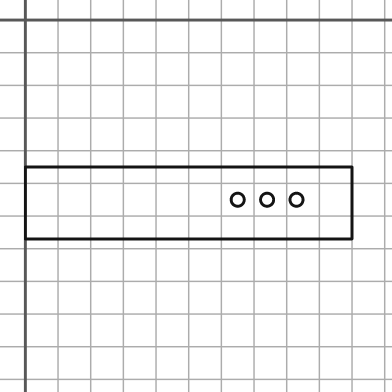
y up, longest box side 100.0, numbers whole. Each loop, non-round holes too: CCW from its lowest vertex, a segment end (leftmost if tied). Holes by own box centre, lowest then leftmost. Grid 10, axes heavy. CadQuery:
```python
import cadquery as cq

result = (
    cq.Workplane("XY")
    .moveTo(0.0, -67.0)
    .lineTo(100.0, -67.0)
    .lineTo(100.0, -45.0)
    .lineTo(0.0, -45.0)
    .close()
    .moveTo(65.0, -55.0)
    .circle(2.0)
    .moveTo(74.0, -55.0)
    .circle(2.0)
    .moveTo(83.0, -55.0)
    .circle(2.0)
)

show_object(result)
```